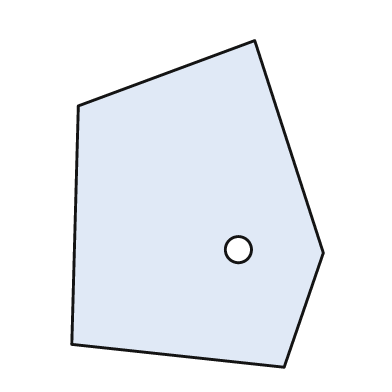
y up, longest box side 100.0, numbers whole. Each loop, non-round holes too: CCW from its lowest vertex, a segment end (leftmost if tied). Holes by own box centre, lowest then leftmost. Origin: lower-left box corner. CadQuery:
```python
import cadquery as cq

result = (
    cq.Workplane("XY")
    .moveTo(65.0, 0.0)
    .lineTo(77.0, 35.0)
    .lineTo(56.0, 100.0)
    .lineTo(2.0, 80.0)
    .lineTo(0.0, 7.0)
    .close()
    .moveTo(51.0, 36.0)
    .circle(4.0)
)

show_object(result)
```